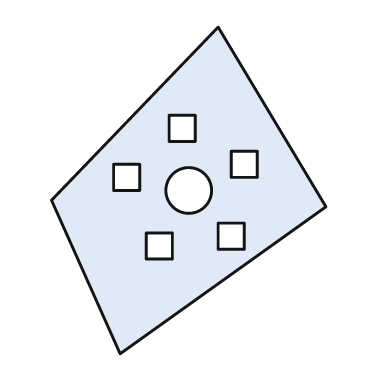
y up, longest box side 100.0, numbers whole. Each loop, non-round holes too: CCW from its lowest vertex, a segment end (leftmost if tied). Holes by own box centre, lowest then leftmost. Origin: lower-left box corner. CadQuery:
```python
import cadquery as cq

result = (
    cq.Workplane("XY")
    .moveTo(21.0, 0.0)
    .lineTo(84.0, 45.0)
    .lineTo(51.0, 100.0)
    .lineTo(0.0, 47.0)
    .close()
    .moveTo(29.0, 29.0)
    .lineTo(37.0, 29.0)
    .lineTo(37.0, 37.0)
    .lineTo(29.0, 37.0)
    .close()
    .moveTo(51.0, 32.0)
    .lineTo(59.0, 32.0)
    .lineTo(59.0, 40.0)
    .lineTo(51.0, 40.0)
    .close()
    .moveTo(42.0, 50.0)
    .circle(7.0)
    .moveTo(19.0, 50.0)
    .lineTo(27.0, 50.0)
    .lineTo(27.0, 58.0)
    .lineTo(19.0, 58.0)
    .close()
    .moveTo(55.0, 54.0)
    .lineTo(63.0, 54.0)
    .lineTo(63.0, 62.0)
    .lineTo(55.0, 62.0)
    .close()
    .moveTo(36.0, 65.0)
    .lineTo(44.0, 65.0)
    .lineTo(44.0, 73.0)
    .lineTo(36.0, 73.0)
    .close()
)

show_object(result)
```